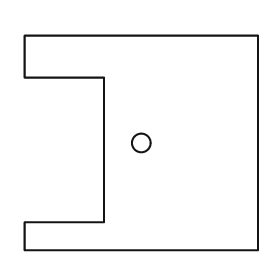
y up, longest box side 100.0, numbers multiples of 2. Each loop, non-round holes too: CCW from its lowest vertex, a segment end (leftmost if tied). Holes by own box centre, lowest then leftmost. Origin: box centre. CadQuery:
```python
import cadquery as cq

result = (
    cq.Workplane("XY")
    .moveTo(-50.0, -46.0)
    .lineTo(50.0, -46.0)
    .lineTo(50.0, 46.0)
    .lineTo(-50.0, 46.0)
    .lineTo(-50.0, 28.0)
    .lineTo(-16.0, 28.0)
    .lineTo(-16.0, -34.0)
    .lineTo(-50.0, -34.0)
    .close()
    .moveTo(0.0, 0.0)
    .circle(4.0)
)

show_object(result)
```